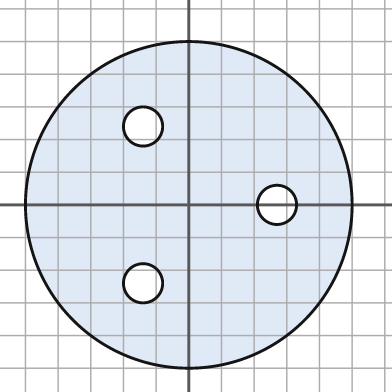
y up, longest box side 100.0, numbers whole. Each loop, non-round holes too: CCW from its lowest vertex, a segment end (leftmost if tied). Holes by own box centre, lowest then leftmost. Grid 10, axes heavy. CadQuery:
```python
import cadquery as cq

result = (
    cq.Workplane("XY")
    .moveTo(0.0, 0.0)
    .circle(50.0)
    .moveTo(-14.0, -24.0)
    .circle(6.0)
    .moveTo(27.0, 0.0)
    .circle(6.0)
    .moveTo(-14.0, 24.0)
    .circle(6.0)
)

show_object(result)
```